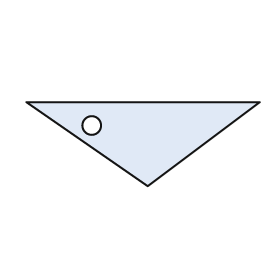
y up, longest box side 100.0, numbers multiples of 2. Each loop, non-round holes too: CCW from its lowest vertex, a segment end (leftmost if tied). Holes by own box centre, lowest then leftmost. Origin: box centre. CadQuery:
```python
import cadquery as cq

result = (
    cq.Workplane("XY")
    .moveTo(2.0, -18.0)
    .lineTo(50.0, 18.0)
    .lineTo(-50.0, 18.0)
    .close()
    .moveTo(-22.0, 8.0)
    .circle(4.0)
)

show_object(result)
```